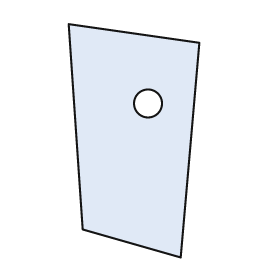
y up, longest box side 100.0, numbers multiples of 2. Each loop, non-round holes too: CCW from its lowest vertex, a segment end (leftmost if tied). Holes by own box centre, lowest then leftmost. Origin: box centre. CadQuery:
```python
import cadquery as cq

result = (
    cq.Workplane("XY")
    .moveTo(20.0, -50.0)
    .lineTo(28.0, 42.0)
    .lineTo(-28.0, 50.0)
    .lineTo(-22.0, -38.0)
    .close()
    .moveTo(6.0, 16.0)
    .circle(6.0)
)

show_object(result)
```